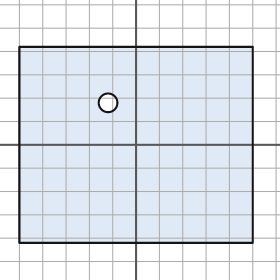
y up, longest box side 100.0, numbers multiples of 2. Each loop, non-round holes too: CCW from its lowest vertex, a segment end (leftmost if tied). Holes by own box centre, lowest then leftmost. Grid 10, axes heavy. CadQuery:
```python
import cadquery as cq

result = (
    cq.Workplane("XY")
    .moveTo(-50.0, -42.0)
    .lineTo(50.0, -42.0)
    .lineTo(50.0, 42.0)
    .lineTo(-50.0, 42.0)
    .close()
    .moveTo(-12.0, 18.0)
    .circle(4.0)
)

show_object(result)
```